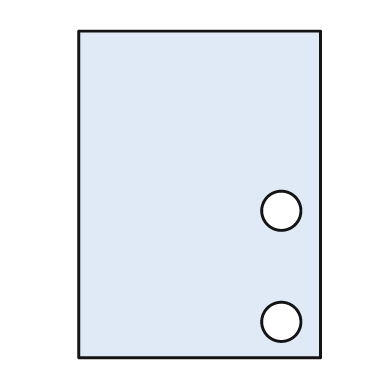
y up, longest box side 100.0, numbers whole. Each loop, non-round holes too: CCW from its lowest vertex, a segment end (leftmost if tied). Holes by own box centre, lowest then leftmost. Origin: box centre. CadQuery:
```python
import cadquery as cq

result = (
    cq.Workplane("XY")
    .moveTo(-37.0, -50.0)
    .lineTo(37.0, -50.0)
    .lineTo(37.0, 50.0)
    .lineTo(-37.0, 50.0)
    .close()
    .moveTo(25.0, -39.0)
    .circle(6.0)
    .moveTo(25.0, -5.0)
    .circle(6.0)
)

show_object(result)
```